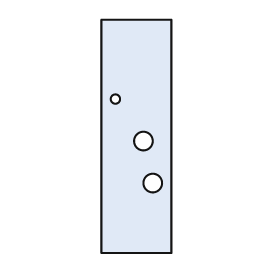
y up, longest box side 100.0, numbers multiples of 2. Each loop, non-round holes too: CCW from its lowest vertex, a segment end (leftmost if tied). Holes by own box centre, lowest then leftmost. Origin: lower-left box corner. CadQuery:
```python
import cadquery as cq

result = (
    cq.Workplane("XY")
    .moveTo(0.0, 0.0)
    .lineTo(30.0, 0.0)
    .lineTo(30.0, 100.0)
    .lineTo(0.0, 100.0)
    .close()
    .moveTo(22.0, 30.0)
    .circle(4.0)
    .moveTo(18.0, 48.0)
    .circle(4.0)
    .moveTo(6.0, 66.0)
    .circle(2.0)
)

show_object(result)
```